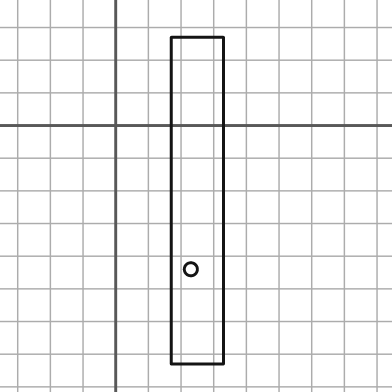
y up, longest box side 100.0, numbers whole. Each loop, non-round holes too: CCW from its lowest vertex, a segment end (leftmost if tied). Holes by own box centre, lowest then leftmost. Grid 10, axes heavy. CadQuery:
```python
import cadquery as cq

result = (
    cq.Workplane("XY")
    .moveTo(17.0, -73.0)
    .lineTo(33.0, -73.0)
    .lineTo(33.0, 27.0)
    .lineTo(17.0, 27.0)
    .close()
    .moveTo(23.0, -44.0)
    .circle(2.0)
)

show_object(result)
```